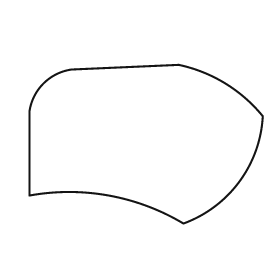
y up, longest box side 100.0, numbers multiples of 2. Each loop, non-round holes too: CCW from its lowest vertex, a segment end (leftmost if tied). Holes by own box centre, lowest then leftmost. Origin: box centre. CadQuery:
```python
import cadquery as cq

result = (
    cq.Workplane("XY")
    .moveTo(16.0, -34.0)
    .threePointArc((40.0, -16.0), (50.0, 12.0))
    .threePointArc((34.0, 26.0), (14.0, 34.0))
    .lineTo(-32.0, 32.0)
    .threePointArc((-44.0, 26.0), (-50.0, 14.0))
    .lineTo(-50.0, -22.0)
    .threePointArc((-16.0, -22.0), (16.0, -34.0))
    .close()
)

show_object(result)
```